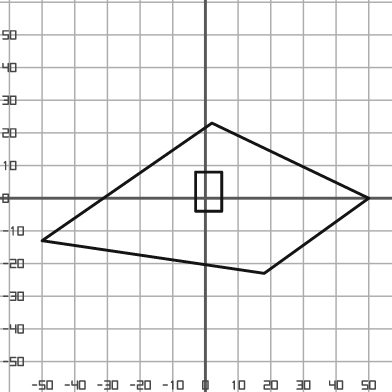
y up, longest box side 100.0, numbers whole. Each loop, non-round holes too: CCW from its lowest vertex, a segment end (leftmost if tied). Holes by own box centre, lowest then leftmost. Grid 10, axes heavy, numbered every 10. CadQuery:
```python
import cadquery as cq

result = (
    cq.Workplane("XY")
    .moveTo(18.0, -23.0)
    .lineTo(50.0, 0.0)
    .lineTo(2.0, 23.0)
    .lineTo(-50.0, -13.0)
    .close()
    .moveTo(-3.0, -4.0)
    .lineTo(5.0, -4.0)
    .lineTo(5.0, 8.0)
    .lineTo(-3.0, 8.0)
    .close()
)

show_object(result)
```